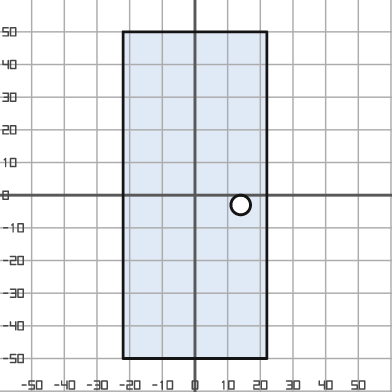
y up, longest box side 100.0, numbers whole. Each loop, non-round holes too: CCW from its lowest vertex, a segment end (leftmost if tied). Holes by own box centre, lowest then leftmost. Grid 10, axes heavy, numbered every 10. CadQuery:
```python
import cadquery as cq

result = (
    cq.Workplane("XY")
    .moveTo(-22.0, -50.0)
    .lineTo(22.0, -50.0)
    .lineTo(22.0, 50.0)
    .lineTo(-22.0, 50.0)
    .close()
    .moveTo(14.0, -3.0)
    .circle(3.0)
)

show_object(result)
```